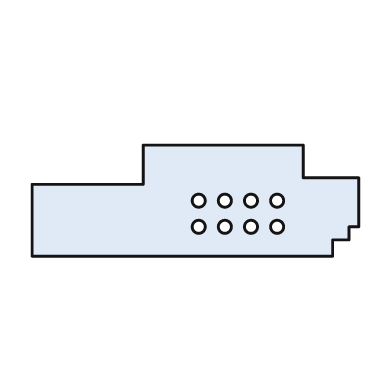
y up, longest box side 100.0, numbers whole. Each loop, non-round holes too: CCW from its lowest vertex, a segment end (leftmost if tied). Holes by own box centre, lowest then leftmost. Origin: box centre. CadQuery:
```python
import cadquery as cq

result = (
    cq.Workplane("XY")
    .moveTo(-50.0, -17.0)
    .lineTo(42.0, -17.0)
    .lineTo(42.0, -12.0)
    .lineTo(47.0, -12.0)
    .lineTo(47.0, -8.0)
    .lineTo(50.0, -8.0)
    .lineTo(50.0, 7.0)
    .lineTo(33.0, 7.0)
    .lineTo(33.0, 17.0)
    .lineTo(-16.0, 17.0)
    .lineTo(-16.0, 5.0)
    .lineTo(-50.0, 5.0)
    .close()
    .moveTo(1.0, -8.0)
    .circle(2.0)
    .moveTo(9.0, -8.0)
    .circle(2.0)
    .moveTo(17.0, -8.0)
    .circle(2.0)
    .moveTo(25.0, -8.0)
    .circle(2.0)
    .moveTo(1.0, 0.0)
    .circle(2.0)
    .moveTo(9.0, 0.0)
    .circle(2.0)
    .moveTo(17.0, 0.0)
    .circle(2.0)
    .moveTo(25.0, 0.0)
    .circle(2.0)
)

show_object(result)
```